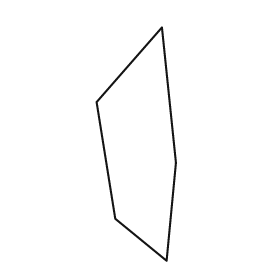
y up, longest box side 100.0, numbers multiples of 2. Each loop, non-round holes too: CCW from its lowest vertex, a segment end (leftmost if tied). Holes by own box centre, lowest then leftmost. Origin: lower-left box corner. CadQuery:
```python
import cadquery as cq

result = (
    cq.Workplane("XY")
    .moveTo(30.0, 0.0)
    .lineTo(34.0, 42.0)
    .lineTo(28.0, 100.0)
    .lineTo(0.0, 68.0)
    .lineTo(8.0, 18.0)
    .close()
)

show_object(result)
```